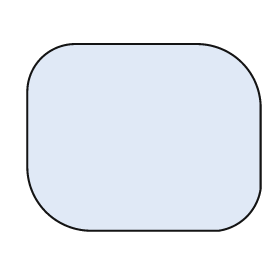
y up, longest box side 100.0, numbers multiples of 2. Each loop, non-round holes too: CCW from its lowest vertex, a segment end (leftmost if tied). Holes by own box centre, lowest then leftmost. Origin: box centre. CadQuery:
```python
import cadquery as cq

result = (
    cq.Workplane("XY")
    .moveTo(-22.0, -40.0)
    .lineTo(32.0, -40.0)
    .threePointArc((44.0, -34.0), (50.0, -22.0))
    .lineTo(50.0, 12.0)
    .threePointArc((42.0, 32.0), (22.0, 40.0))
    .lineTo(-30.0, 40.0)
    .threePointArc((-44.0, 34.0), (-50.0, 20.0))
    .lineTo(-50.0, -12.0)
    .threePointArc((-42.0, -32.0), (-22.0, -40.0))
    .close()
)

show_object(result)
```